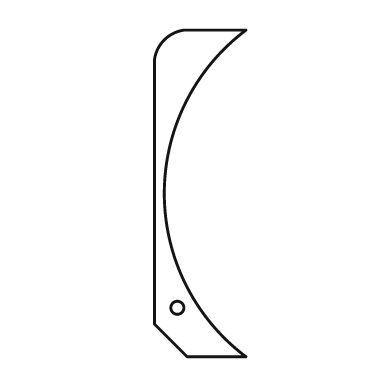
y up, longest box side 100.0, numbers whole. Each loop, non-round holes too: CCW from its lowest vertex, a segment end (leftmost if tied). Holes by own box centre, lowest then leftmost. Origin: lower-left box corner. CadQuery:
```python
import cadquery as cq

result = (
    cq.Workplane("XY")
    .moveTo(10.0, 0.0)
    .lineTo(28.0, 0.0)
    .threePointArc((3.0, 50.0), (28.0, 100.0))
    .lineTo(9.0, 100.0)
    .threePointArc((3.0, 97.0), (0.0, 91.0))
    .lineTo(0.0, 10.0)
    .close()
    .moveTo(7.0, 15.0)
    .circle(2.0)
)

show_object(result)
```